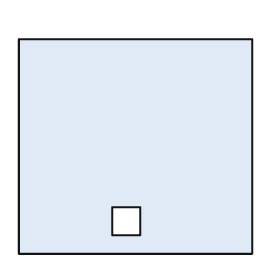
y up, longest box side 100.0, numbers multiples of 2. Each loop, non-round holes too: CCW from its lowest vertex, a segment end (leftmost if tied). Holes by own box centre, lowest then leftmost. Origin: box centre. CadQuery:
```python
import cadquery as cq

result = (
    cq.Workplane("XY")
    .moveTo(-50.0, -46.0)
    .lineTo(50.0, -46.0)
    .lineTo(50.0, 46.0)
    .lineTo(-50.0, 46.0)
    .close()
    .moveTo(-10.0, -38.0)
    .lineTo(2.0, -38.0)
    .lineTo(2.0, -26.0)
    .lineTo(-10.0, -26.0)
    .close()
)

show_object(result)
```